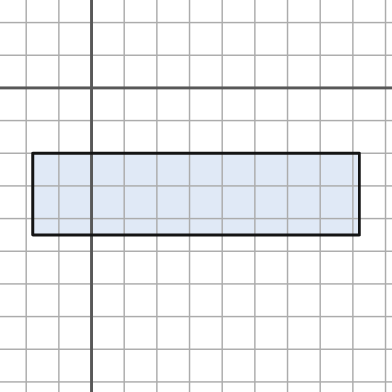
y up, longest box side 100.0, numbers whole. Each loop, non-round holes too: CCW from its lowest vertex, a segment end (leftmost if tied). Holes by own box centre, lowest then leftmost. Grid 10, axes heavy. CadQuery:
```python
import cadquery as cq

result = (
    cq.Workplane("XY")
    .moveTo(-18.0, -45.0)
    .lineTo(82.0, -45.0)
    .lineTo(82.0, -20.0)
    .lineTo(-18.0, -20.0)
    .close()
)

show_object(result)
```